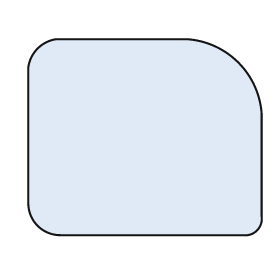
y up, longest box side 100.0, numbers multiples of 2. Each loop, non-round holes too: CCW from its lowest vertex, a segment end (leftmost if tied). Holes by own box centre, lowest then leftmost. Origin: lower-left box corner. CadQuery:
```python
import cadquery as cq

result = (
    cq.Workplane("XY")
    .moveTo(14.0, 0.0)
    .lineTo(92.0, 0.0)
    .threePointArc((98.0, 2.0), (100.0, 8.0))
    .lineTo(100.0, 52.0)
    .threePointArc((90.0, 74.0), (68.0, 84.0))
    .lineTo(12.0, 84.0)
    .threePointArc((4.0, 80.0), (0.0, 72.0))
    .lineTo(0.0, 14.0)
    .threePointArc((4.0, 4.0), (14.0, 0.0))
    .close()
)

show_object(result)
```